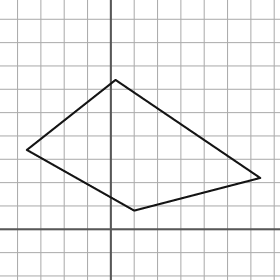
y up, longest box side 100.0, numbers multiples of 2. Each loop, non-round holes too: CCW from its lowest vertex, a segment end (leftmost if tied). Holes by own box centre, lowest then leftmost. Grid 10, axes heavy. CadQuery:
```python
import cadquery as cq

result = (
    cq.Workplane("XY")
    .moveTo(10.0, 8.0)
    .lineTo(64.0, 22.0)
    .lineTo(2.0, 64.0)
    .lineTo(-36.0, 34.0)
    .close()
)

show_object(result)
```